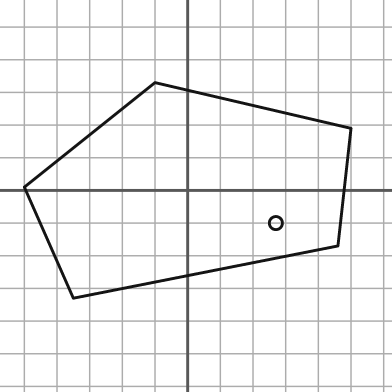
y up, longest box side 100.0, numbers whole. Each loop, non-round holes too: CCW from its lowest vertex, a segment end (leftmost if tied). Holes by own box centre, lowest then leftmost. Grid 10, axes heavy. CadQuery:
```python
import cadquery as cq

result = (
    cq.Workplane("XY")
    .moveTo(-35.0, -33.0)
    .lineTo(46.0, -17.0)
    .lineTo(50.0, 19.0)
    .lineTo(-10.0, 33.0)
    .lineTo(-50.0, 1.0)
    .close()
    .moveTo(27.0, -10.0)
    .circle(2.0)
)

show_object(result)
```